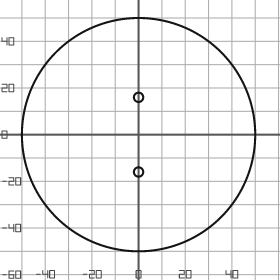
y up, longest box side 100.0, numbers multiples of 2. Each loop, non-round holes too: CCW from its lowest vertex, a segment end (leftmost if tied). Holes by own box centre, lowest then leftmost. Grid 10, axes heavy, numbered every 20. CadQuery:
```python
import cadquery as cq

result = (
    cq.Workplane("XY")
    .moveTo(0.0, 0.0)
    .circle(50.0)
    .moveTo(0.0, -16.0)
    .circle(2.0)
    .moveTo(0.0, 16.0)
    .circle(2.0)
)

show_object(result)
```